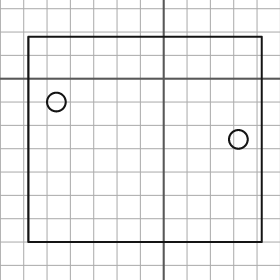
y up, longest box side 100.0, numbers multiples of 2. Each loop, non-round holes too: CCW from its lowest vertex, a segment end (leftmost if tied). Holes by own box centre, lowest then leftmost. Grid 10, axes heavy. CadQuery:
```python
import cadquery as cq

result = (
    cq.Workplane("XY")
    .moveTo(-58.0, -70.0)
    .lineTo(42.0, -70.0)
    .lineTo(42.0, 18.0)
    .lineTo(-58.0, 18.0)
    .close()
    .moveTo(32.0, -26.0)
    .circle(4.0)
    .moveTo(-46.0, -10.0)
    .circle(4.0)
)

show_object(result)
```